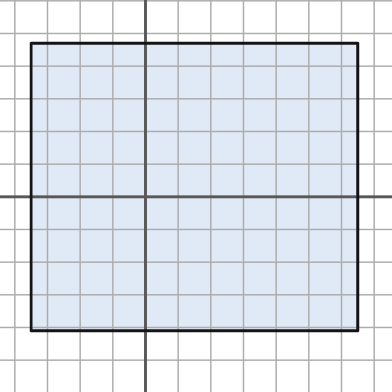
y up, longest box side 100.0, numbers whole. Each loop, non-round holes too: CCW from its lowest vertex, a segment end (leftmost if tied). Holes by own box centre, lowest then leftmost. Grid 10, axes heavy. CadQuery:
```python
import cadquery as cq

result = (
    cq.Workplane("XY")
    .moveTo(-35.0, -41.0)
    .lineTo(65.0, -41.0)
    .lineTo(65.0, 47.0)
    .lineTo(-35.0, 47.0)
    .close()
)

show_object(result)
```